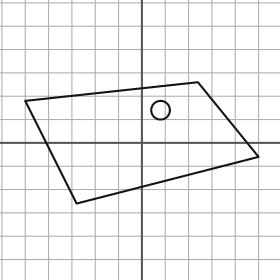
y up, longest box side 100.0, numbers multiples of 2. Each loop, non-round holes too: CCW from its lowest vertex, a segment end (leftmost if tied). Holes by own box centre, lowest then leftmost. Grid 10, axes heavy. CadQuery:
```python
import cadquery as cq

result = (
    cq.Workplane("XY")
    .moveTo(-28.0, -26.0)
    .lineTo(50.0, -6.0)
    .lineTo(24.0, 26.0)
    .lineTo(-50.0, 18.0)
    .close()
    .moveTo(8.0, 14.0)
    .circle(4.0)
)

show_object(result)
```